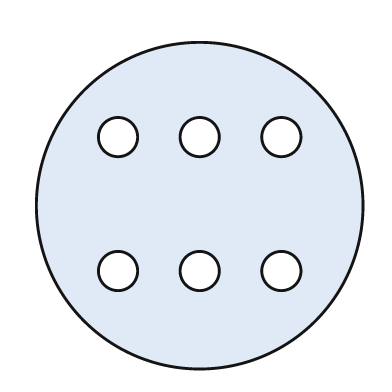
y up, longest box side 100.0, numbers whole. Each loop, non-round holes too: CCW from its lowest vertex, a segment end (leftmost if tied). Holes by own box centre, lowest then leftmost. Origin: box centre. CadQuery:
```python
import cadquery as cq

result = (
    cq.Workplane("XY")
    .moveTo(0.0, 0.0)
    .circle(50.0)
    .moveTo(-25.0, -20.0)
    .circle(6.0)
    .moveTo(0.0, -20.0)
    .circle(6.0)
    .moveTo(25.0, -20.0)
    .circle(6.0)
    .moveTo(-25.0, 21.0)
    .circle(6.0)
    .moveTo(0.0, 21.0)
    .circle(6.0)
    .moveTo(25.0, 21.0)
    .circle(6.0)
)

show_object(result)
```